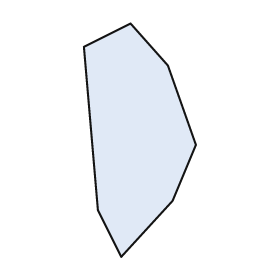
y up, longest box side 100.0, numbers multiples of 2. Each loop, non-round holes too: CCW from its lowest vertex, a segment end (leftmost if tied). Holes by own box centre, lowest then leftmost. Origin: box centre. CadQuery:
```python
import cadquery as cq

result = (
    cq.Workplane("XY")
    .moveTo(-8.0, -50.0)
    .lineTo(14.0, -26.0)
    .lineTo(24.0, -2.0)
    .lineTo(12.0, 32.0)
    .lineTo(-4.0, 50.0)
    .lineTo(-24.0, 40.0)
    .lineTo(-18.0, -30.0)
    .close()
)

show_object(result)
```